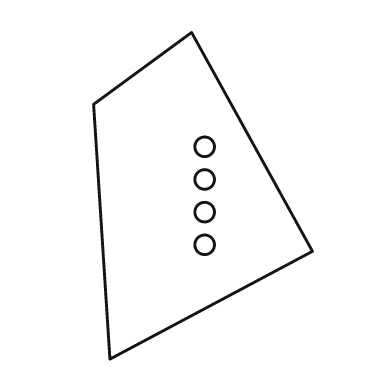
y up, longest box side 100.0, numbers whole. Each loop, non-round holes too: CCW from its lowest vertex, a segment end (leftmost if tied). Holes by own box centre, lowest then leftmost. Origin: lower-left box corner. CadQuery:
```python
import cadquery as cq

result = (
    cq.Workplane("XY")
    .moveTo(5.0, 0.0)
    .lineTo(67.0, 33.0)
    .lineTo(30.0, 100.0)
    .lineTo(0.0, 78.0)
    .close()
    .moveTo(34.0, 35.0)
    .circle(3.0)
    .moveTo(34.0, 45.0)
    .circle(3.0)
    .moveTo(34.0, 55.0)
    .circle(3.0)
    .moveTo(34.0, 65.0)
    .circle(3.0)
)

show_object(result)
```